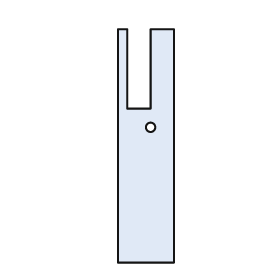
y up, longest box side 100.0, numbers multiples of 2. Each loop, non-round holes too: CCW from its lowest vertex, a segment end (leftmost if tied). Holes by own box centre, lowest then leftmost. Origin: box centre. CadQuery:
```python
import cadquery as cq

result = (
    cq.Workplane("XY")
    .moveTo(-12.0, -50.0)
    .lineTo(12.0, -50.0)
    .lineTo(12.0, 50.0)
    .lineTo(2.0, 50.0)
    .lineTo(2.0, 16.0)
    .lineTo(-8.0, 16.0)
    .lineTo(-8.0, 50.0)
    .lineTo(-12.0, 50.0)
    .close()
    .moveTo(2.0, 8.0)
    .circle(2.0)
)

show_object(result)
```